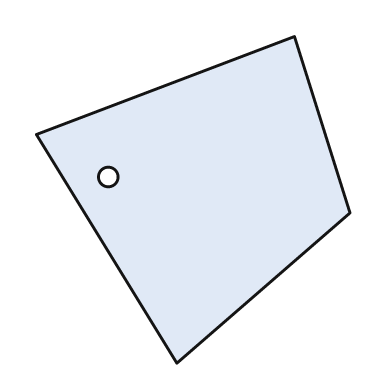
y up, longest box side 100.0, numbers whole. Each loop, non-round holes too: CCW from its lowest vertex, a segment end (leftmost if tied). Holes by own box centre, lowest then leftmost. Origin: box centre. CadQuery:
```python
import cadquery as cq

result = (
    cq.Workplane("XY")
    .moveTo(-5.0, -50.0)
    .lineTo(48.0, -4.0)
    .lineTo(31.0, 50.0)
    .lineTo(-48.0, 20.0)
    .close()
    .moveTo(-26.0, 7.0)
    .circle(3.0)
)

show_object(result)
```